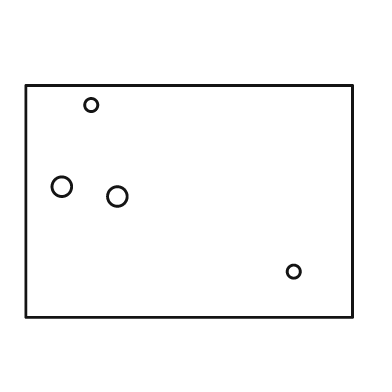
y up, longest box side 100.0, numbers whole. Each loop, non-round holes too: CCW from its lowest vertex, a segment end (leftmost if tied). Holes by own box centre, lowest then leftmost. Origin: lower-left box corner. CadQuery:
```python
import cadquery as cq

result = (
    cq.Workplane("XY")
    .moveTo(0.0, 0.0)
    .lineTo(100.0, 0.0)
    .lineTo(100.0, 71.0)
    .lineTo(0.0, 71.0)
    .close()
    .moveTo(82.0, 14.0)
    .circle(2.0)
    .moveTo(28.0, 37.0)
    .circle(3.0)
    .moveTo(11.0, 40.0)
    .circle(3.0)
    .moveTo(20.0, 65.0)
    .circle(2.0)
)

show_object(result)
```